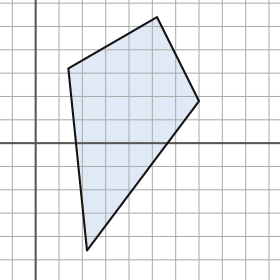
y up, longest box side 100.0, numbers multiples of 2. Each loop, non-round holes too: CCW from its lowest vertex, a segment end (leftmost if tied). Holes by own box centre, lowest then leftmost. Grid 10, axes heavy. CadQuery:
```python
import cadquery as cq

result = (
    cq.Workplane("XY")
    .moveTo(22.0, -46.0)
    .lineTo(70.0, 18.0)
    .lineTo(52.0, 54.0)
    .lineTo(14.0, 32.0)
    .close()
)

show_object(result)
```